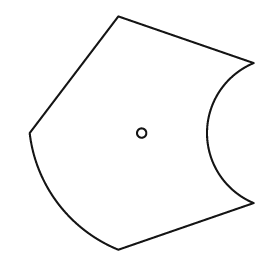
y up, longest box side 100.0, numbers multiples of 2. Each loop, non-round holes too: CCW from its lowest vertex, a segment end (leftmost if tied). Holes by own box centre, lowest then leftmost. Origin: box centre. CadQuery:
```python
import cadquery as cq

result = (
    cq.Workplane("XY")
    .moveTo(-10.0, -50.0)
    .lineTo(48.0, -30.0)
    .threePointArc((28.0, 0.0), (48.0, 30.0))
    .lineTo(-10.0, 50.0)
    .lineTo(-48.0, 0.0)
    .threePointArc((-36.0, -30.0), (-10.0, -50.0))
    .close()
    .moveTo(0.0, 0.0)
    .circle(2.0)
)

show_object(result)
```